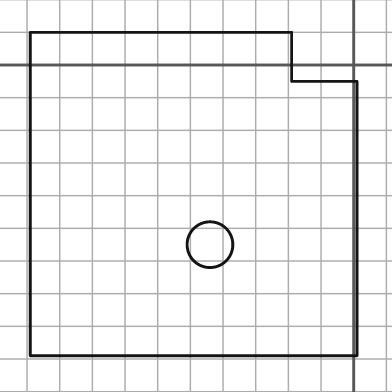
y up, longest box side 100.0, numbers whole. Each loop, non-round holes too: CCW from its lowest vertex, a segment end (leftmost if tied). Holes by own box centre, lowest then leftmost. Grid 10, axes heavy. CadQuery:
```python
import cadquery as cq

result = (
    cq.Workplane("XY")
    .moveTo(-99.0, -89.0)
    .lineTo(1.0, -89.0)
    .lineTo(1.0, -5.0)
    .lineTo(-19.0, -5.0)
    .lineTo(-19.0, 10.0)
    .lineTo(-99.0, 10.0)
    .close()
    .moveTo(-44.0, -55.0)
    .circle(7.0)
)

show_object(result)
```